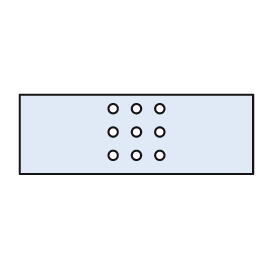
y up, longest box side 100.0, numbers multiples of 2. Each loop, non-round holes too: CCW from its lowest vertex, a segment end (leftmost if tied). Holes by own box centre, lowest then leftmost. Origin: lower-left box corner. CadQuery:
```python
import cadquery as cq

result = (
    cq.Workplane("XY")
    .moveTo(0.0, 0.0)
    .lineTo(100.0, 0.0)
    .lineTo(100.0, 34.0)
    .lineTo(0.0, 34.0)
    .close()
    .moveTo(40.0, 8.0)
    .circle(2.0)
    .moveTo(50.0, 8.0)
    .circle(2.0)
    .moveTo(60.0, 8.0)
    .circle(2.0)
    .moveTo(40.0, 18.0)
    .circle(2.0)
    .moveTo(50.0, 18.0)
    .circle(2.0)
    .moveTo(60.0, 18.0)
    .circle(2.0)
    .moveTo(40.0, 28.0)
    .circle(2.0)
    .moveTo(50.0, 28.0)
    .circle(2.0)
    .moveTo(60.0, 28.0)
    .circle(2.0)
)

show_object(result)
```